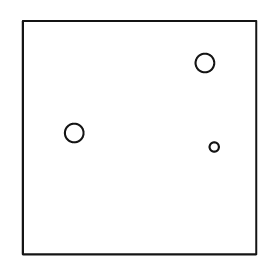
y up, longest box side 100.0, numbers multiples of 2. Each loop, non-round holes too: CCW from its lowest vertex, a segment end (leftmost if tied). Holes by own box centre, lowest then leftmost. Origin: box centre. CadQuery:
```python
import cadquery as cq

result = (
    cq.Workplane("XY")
    .moveTo(-50.0, -50.0)
    .lineTo(50.0, -50.0)
    .lineTo(50.0, 50.0)
    .lineTo(-50.0, 50.0)
    .close()
    .moveTo(32.0, -4.0)
    .circle(2.0)
    .moveTo(-28.0, 2.0)
    .circle(4.0)
    .moveTo(28.0, 32.0)
    .circle(4.0)
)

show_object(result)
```